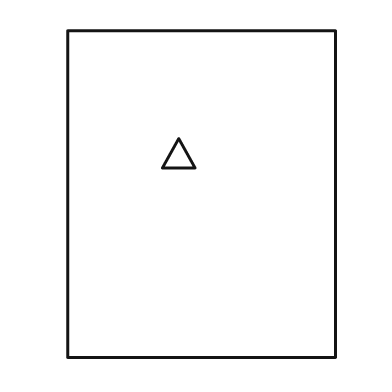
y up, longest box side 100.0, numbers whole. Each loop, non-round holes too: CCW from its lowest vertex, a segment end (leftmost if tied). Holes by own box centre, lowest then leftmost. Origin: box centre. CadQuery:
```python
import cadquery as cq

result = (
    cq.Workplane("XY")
    .moveTo(-41.0, -50.0)
    .lineTo(41.0, -50.0)
    .lineTo(41.0, 50.0)
    .lineTo(-41.0, 50.0)
    .close()
    .moveTo(-12.0, 8.0)
    .lineTo(-2.0, 8.0)
    .lineTo(-7.0, 17.0)
    .close()
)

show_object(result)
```